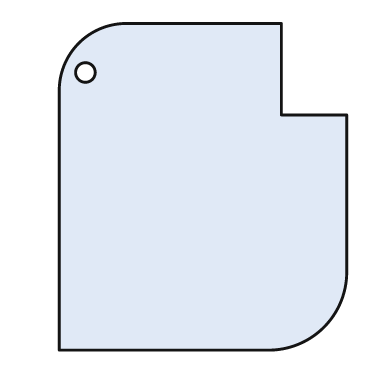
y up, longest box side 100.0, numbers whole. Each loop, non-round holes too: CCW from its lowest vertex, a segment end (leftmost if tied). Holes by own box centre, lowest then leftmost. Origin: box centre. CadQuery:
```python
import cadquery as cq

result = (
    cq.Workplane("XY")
    .moveTo(-44.0, -50.0)
    .lineTo(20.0, -50.0)
    .threePointArc((37.0, -43.0), (44.0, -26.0))
    .lineTo(44.0, 22.0)
    .lineTo(24.0, 22.0)
    .lineTo(24.0, 50.0)
    .lineTo(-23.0, 50.0)
    .threePointArc((-38.0, 44.0), (-44.0, 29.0))
    .close()
    .moveTo(-36.0, 35.0)
    .circle(3.0)
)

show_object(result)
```